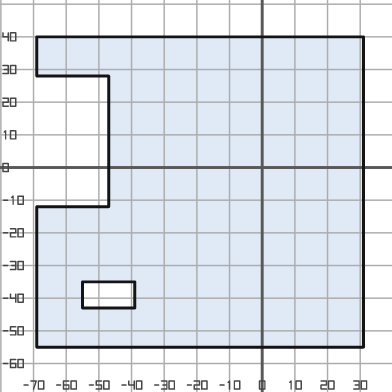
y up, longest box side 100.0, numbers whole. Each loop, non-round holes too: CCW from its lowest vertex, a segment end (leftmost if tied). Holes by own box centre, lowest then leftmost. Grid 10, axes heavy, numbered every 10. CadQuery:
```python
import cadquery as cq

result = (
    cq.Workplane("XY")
    .moveTo(-69.0, -55.0)
    .lineTo(31.0, -55.0)
    .lineTo(31.0, 40.0)
    .lineTo(-69.0, 40.0)
    .lineTo(-69.0, 28.0)
    .lineTo(-47.0, 28.0)
    .lineTo(-47.0, -12.0)
    .lineTo(-69.0, -12.0)
    .close()
    .moveTo(-55.0, -43.0)
    .lineTo(-39.0, -43.0)
    .lineTo(-39.0, -35.0)
    .lineTo(-55.0, -35.0)
    .close()
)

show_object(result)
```